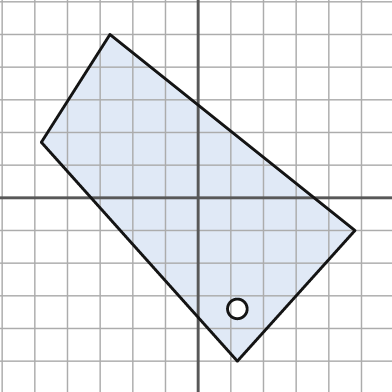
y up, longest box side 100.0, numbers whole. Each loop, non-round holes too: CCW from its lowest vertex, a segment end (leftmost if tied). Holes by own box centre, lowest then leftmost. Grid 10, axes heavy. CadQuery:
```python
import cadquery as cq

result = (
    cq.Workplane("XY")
    .moveTo(12.0, -50.0)
    .lineTo(48.0, -10.0)
    .lineTo(-27.0, 50.0)
    .lineTo(-48.0, 17.0)
    .close()
    .moveTo(12.0, -34.0)
    .circle(3.0)
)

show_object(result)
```